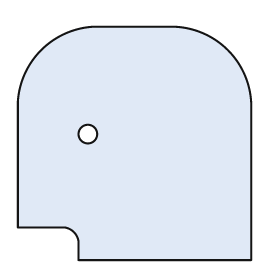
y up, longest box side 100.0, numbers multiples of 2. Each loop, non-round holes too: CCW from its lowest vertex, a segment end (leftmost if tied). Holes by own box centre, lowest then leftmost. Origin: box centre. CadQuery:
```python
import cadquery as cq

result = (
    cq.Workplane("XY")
    .moveTo(-24.0, -50.0)
    .lineTo(50.0, -50.0)
    .lineTo(50.0, 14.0)
    .threePointArc((40.0, 40.0), (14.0, 50.0))
    .lineTo(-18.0, 50.0)
    .threePointArc((-40.0, 40.0), (-50.0, 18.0))
    .lineTo(-50.0, -36.0)
    .lineTo(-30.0, -36.0)
    .threePointArc((-26.0, -38.0), (-24.0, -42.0))
    .close()
    .moveTo(-20.0, 4.0)
    .circle(4.0)
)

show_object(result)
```